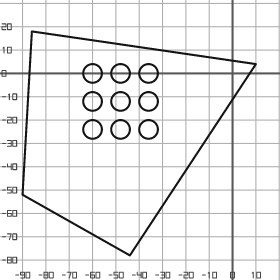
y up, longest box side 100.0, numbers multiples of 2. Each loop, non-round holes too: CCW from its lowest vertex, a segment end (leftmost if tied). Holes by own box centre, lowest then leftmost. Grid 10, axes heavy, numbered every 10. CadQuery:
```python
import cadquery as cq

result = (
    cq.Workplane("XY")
    .moveTo(-44.0, -78.0)
    .lineTo(10.0, 4.0)
    .lineTo(-86.0, 18.0)
    .lineTo(-90.0, -52.0)
    .close()
    .moveTo(-60.0, -24.0)
    .circle(4.0)
    .moveTo(-48.0, -24.0)
    .circle(4.0)
    .moveTo(-36.0, -24.0)
    .circle(4.0)
    .moveTo(-60.0, -12.0)
    .circle(4.0)
    .moveTo(-48.0, -12.0)
    .circle(4.0)
    .moveTo(-36.0, -12.0)
    .circle(4.0)
    .moveTo(-60.0, 0.0)
    .circle(4.0)
    .moveTo(-48.0, 0.0)
    .circle(4.0)
    .moveTo(-36.0, 0.0)
    .circle(4.0)
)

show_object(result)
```